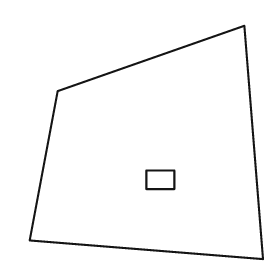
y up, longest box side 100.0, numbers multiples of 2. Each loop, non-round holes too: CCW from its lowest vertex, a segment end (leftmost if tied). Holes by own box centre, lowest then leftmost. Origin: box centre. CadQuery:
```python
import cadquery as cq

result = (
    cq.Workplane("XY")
    .moveTo(50.0, -50.0)
    .lineTo(42.0, 50.0)
    .lineTo(-38.0, 22.0)
    .lineTo(-50.0, -42.0)
    .close()
    .moveTo(0.0, -20.0)
    .lineTo(12.0, -20.0)
    .lineTo(12.0, -12.0)
    .lineTo(0.0, -12.0)
    .close()
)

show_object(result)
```